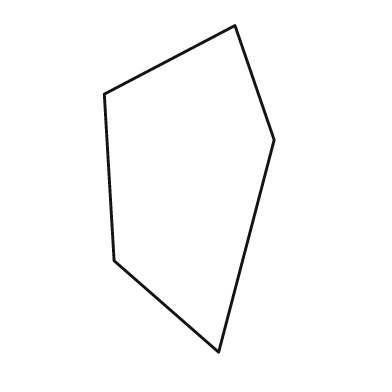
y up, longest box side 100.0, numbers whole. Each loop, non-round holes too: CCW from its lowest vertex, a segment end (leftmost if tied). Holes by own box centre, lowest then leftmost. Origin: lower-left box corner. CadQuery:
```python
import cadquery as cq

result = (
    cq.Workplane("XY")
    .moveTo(35.0, 0.0)
    .lineTo(52.0, 65.0)
    .lineTo(40.0, 100.0)
    .lineTo(0.0, 79.0)
    .lineTo(3.0, 28.0)
    .close()
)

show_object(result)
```